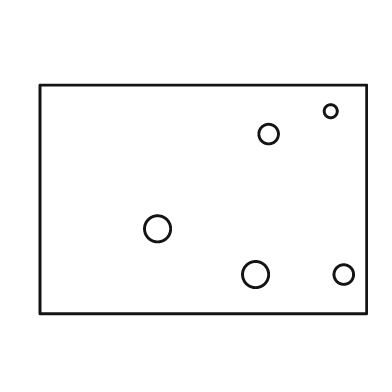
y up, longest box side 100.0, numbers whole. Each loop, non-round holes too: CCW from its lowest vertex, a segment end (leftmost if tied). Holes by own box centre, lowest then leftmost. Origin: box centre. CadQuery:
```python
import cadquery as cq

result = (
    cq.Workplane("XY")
    .moveTo(-50.0, -35.0)
    .lineTo(50.0, -35.0)
    .lineTo(50.0, 35.0)
    .lineTo(-50.0, 35.0)
    .close()
    .moveTo(16.0, -23.0)
    .circle(4.0)
    .moveTo(43.0, -23.0)
    .circle(3.0)
    .moveTo(-14.0, -9.0)
    .circle(4.0)
    .moveTo(20.0, 20.0)
    .circle(3.0)
    .moveTo(39.0, 27.0)
    .circle(2.0)
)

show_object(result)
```